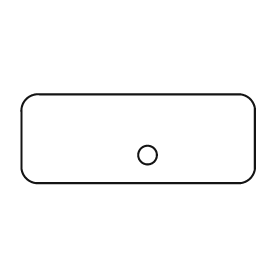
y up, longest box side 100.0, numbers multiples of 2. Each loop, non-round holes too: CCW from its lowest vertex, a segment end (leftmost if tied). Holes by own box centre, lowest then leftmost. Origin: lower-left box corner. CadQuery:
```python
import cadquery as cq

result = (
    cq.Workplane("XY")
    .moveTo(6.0, 0.0)
    .lineTo(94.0, 0.0)
    .threePointArc((98.0, 2.0), (100.0, 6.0))
    .lineTo(100.0, 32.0)
    .threePointArc((98.0, 36.0), (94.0, 38.0))
    .lineTo(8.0, 38.0)
    .threePointArc((2.0, 36.0), (0.0, 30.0))
    .lineTo(0.0, 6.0)
    .threePointArc((2.0, 2.0), (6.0, 0.0))
    .close()
    .moveTo(54.0, 12.0)
    .circle(4.0)
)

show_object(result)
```